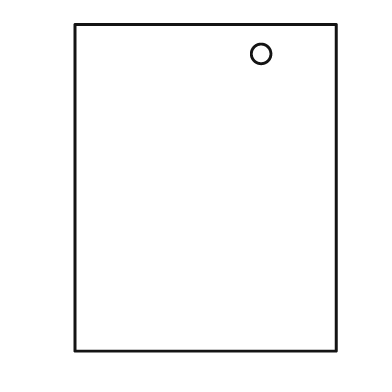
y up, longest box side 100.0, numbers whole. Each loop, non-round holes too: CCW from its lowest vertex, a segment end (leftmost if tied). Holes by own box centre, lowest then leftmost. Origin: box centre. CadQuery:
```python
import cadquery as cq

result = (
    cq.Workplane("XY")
    .moveTo(-40.0, -50.0)
    .lineTo(40.0, -50.0)
    .lineTo(40.0, 50.0)
    .lineTo(-40.0, 50.0)
    .close()
    .moveTo(17.0, 41.0)
    .circle(3.0)
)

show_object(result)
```